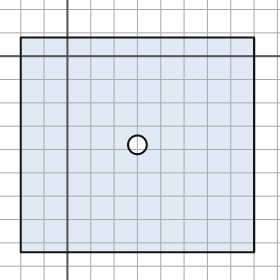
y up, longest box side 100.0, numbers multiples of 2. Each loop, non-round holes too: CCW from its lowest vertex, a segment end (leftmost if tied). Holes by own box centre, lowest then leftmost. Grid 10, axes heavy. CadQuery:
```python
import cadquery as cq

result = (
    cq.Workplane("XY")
    .moveTo(-20.0, -84.0)
    .lineTo(80.0, -84.0)
    .lineTo(80.0, 8.0)
    .lineTo(-20.0, 8.0)
    .close()
    .moveTo(30.0, -38.0)
    .circle(4.0)
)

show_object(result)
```